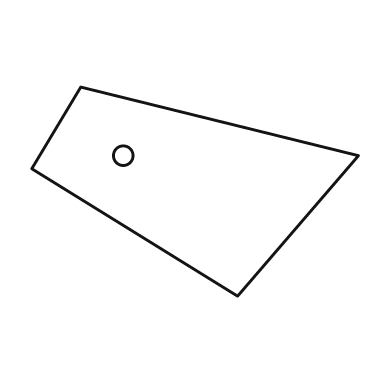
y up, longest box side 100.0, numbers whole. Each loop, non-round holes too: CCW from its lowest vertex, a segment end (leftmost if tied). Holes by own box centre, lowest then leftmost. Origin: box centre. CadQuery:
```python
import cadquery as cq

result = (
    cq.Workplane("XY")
    .moveTo(13.0, -32.0)
    .lineTo(50.0, 11.0)
    .lineTo(-35.0, 32.0)
    .lineTo(-50.0, 7.0)
    .close()
    .moveTo(-22.0, 11.0)
    .circle(3.0)
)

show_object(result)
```